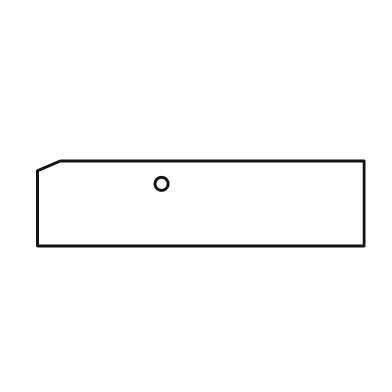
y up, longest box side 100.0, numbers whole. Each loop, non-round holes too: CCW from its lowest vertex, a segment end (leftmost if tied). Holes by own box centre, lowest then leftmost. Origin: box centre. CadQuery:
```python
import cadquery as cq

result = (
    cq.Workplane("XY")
    .moveTo(-50.0, -13.0)
    .lineTo(50.0, -13.0)
    .lineTo(50.0, 13.0)
    .lineTo(-43.0, 13.0)
    .lineTo(-50.0, 10.0)
    .close()
    .moveTo(-12.0, 6.0)
    .circle(2.0)
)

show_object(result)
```